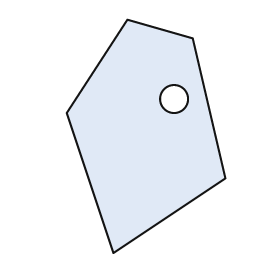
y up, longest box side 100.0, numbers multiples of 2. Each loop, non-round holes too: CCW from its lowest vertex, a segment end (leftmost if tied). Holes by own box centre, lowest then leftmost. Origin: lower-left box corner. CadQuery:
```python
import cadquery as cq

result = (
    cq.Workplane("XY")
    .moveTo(20.0, 0.0)
    .lineTo(68.0, 32.0)
    .lineTo(54.0, 92.0)
    .lineTo(26.0, 100.0)
    .lineTo(0.0, 60.0)
    .close()
    .moveTo(46.0, 66.0)
    .circle(6.0)
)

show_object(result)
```